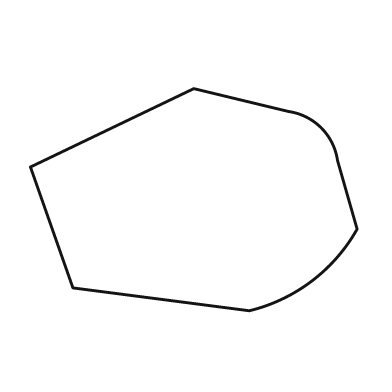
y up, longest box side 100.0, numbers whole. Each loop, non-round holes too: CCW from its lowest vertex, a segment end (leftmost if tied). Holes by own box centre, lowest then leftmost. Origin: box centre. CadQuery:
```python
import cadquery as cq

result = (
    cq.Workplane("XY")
    .moveTo(17.0, -34.0)
    .threePointArc((36.0, -25.0), (50.0, -9.0))
    .lineTo(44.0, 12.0)
    .threePointArc((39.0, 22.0), (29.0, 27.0))
    .lineTo(0.0, 34.0)
    .lineTo(-50.0, 10.0)
    .lineTo(-37.0, -27.0)
    .close()
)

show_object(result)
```